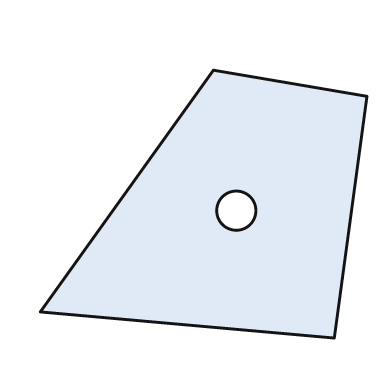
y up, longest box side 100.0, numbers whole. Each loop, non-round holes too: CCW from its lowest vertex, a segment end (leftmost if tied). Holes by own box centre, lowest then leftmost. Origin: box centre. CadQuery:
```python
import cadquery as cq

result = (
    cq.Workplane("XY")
    .moveTo(40.0, -41.0)
    .lineTo(50.0, 33.0)
    .lineTo(3.0, 41.0)
    .lineTo(-50.0, -33.0)
    .close()
    .moveTo(10.0, -2.0)
    .circle(6.0)
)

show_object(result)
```